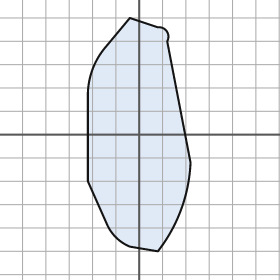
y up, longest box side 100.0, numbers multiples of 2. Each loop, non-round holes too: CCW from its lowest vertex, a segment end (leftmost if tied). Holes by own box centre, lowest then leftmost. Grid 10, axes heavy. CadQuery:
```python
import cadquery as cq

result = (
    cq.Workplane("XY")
    .moveTo(8.0, -50.0)
    .threePointArc((18.0, -32.0), (22.0, -12.0))
    .lineTo(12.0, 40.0)
    .threePointArc((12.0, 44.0), (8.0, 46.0))
    .lineTo(-4.0, 50.0)
    .lineTo(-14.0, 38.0)
    .threePointArc((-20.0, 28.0), (-22.0, 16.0))
    .lineTo(-22.0, -20.0)
    .lineTo(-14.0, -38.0)
    .threePointArc((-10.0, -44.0), (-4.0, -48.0))
    .close()
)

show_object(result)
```